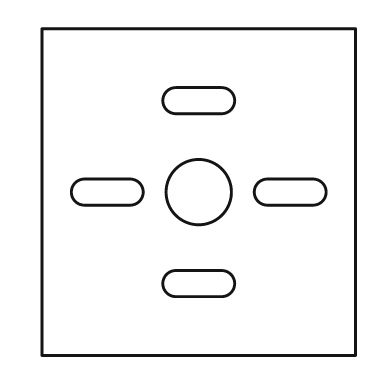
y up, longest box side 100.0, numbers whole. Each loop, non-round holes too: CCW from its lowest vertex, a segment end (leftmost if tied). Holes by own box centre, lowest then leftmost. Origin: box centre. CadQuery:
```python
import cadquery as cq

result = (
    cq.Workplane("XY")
    .moveTo(-48.0, -50.0)
    .lineTo(48.0, -50.0)
    .lineTo(48.0, 50.0)
    .lineTo(-48.0, 50.0)
    .close()
    .moveTo(-7.0, -32.0)
    .lineTo(7.0, -32.0)
    .threePointArc((11.0, -28.0), (7.0, -24.0))
    .lineTo(-7.0, -24.0)
    .threePointArc((-11.0, -28.0), (-7.0, -32.0))
    .close()
    .moveTo(-35.0, -4.0)
    .lineTo(-21.0, -4.0)
    .threePointArc((-17.0, 0.0), (-21.0, 4.0))
    .lineTo(-35.0, 4.0)
    .threePointArc((-39.0, 0.0), (-35.0, -4.0))
    .close()
    .moveTo(0.0, 0.0)
    .circle(10.0)
    .moveTo(21.0, -4.0)
    .lineTo(35.0, -4.0)
    .threePointArc((39.0, 0.0), (35.0, 4.0))
    .lineTo(21.0, 4.0)
    .threePointArc((17.0, 0.0), (21.0, -4.0))
    .close()
    .moveTo(-7.0, 24.0)
    .lineTo(7.0, 24.0)
    .threePointArc((11.0, 28.0), (7.0, 32.0))
    .lineTo(-7.0, 32.0)
    .threePointArc((-11.0, 28.0), (-7.0, 24.0))
    .close()
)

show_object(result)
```